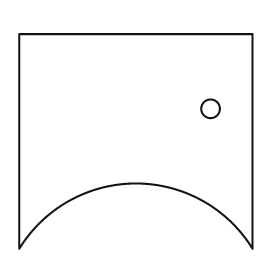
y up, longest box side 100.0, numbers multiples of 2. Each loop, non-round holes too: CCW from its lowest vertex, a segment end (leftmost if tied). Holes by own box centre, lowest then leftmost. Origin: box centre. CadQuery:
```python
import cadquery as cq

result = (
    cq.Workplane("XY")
    .moveTo(-50.0, -46.0)
    .threePointArc((0.0, -18.0), (50.0, -46.0))
    .lineTo(50.0, 46.0)
    .lineTo(-50.0, 46.0)
    .close()
    .moveTo(32.0, 14.0)
    .circle(4.0)
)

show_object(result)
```